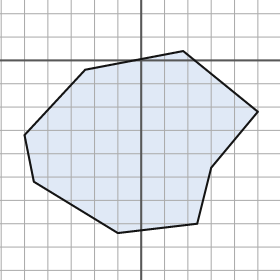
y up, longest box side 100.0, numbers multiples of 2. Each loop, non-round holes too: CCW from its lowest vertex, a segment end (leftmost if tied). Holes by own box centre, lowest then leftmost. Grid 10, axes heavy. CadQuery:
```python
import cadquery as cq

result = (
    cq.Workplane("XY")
    .moveTo(-10.0, -74.0)
    .lineTo(24.0, -70.0)
    .lineTo(30.0, -46.0)
    .lineTo(50.0, -22.0)
    .lineTo(18.0, 4.0)
    .lineTo(-24.0, -4.0)
    .lineTo(-50.0, -32.0)
    .lineTo(-46.0, -52.0)
    .close()
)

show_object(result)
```